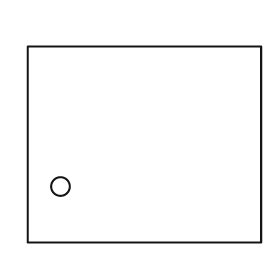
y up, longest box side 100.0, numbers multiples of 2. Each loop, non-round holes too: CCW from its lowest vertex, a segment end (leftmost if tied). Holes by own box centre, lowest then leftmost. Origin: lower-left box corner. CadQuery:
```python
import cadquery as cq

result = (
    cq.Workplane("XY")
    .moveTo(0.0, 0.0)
    .lineTo(100.0, 0.0)
    .lineTo(100.0, 84.0)
    .lineTo(0.0, 84.0)
    .close()
    .moveTo(14.0, 24.0)
    .circle(4.0)
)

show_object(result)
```